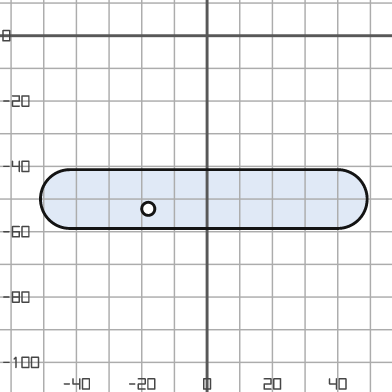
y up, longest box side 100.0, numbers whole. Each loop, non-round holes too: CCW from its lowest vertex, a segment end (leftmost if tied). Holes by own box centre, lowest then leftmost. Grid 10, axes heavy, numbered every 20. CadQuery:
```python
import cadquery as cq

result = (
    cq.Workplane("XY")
    .moveTo(-42.0, -59.0)
    .lineTo(40.0, -59.0)
    .threePointArc((49.0, -50.0), (40.0, -41.0))
    .lineTo(-42.0, -41.0)
    .threePointArc((-51.0, -50.0), (-42.0, -59.0))
    .close()
    .moveTo(-18.0, -53.0)
    .circle(2.0)
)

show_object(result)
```